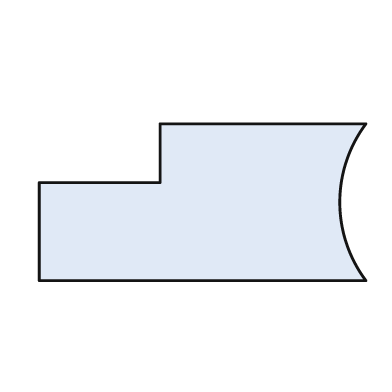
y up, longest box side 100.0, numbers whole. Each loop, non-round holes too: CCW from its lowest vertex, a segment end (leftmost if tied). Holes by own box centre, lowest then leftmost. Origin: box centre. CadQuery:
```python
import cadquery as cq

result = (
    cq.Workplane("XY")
    .moveTo(-50.0, -24.0)
    .lineTo(50.0, -24.0)
    .threePointArc((42.0, 0.0), (50.0, 24.0))
    .lineTo(-13.0, 24.0)
    .lineTo(-13.0, 6.0)
    .lineTo(-50.0, 6.0)
    .close()
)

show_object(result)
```